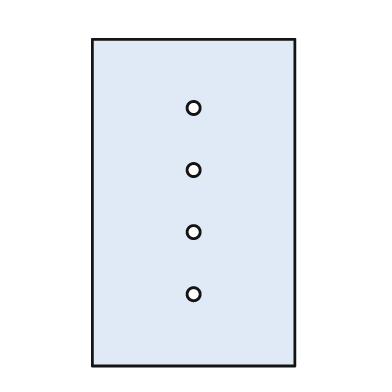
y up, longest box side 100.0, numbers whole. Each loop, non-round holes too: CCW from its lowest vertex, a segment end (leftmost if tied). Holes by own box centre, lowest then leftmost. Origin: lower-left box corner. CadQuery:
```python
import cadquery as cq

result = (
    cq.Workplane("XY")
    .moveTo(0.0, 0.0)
    .lineTo(62.0, 0.0)
    .lineTo(62.0, 100.0)
    .lineTo(0.0, 100.0)
    .close()
    .moveTo(31.0, 22.0)
    .circle(2.0)
    .moveTo(31.0, 41.0)
    .circle(2.0)
    .moveTo(31.0, 60.0)
    .circle(2.0)
    .moveTo(31.0, 79.0)
    .circle(2.0)
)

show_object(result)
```